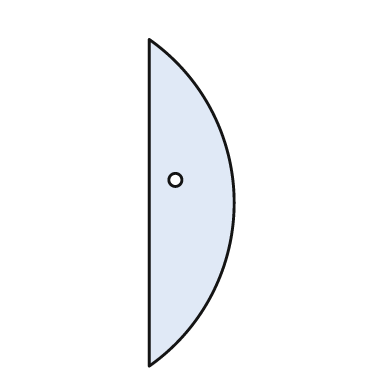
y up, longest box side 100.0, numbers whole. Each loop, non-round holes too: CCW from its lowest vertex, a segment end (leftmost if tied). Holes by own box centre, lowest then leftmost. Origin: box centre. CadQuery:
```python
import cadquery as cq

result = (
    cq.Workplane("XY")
    .moveTo(-13.0, -50.0)
    .threePointArc((13.0, 0.0), (-13.0, 50.0))
    .close()
    .moveTo(-5.0, 7.0)
    .circle(2.0)
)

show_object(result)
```